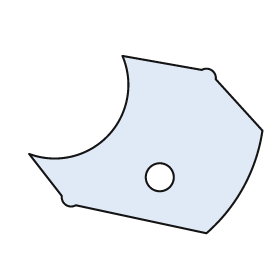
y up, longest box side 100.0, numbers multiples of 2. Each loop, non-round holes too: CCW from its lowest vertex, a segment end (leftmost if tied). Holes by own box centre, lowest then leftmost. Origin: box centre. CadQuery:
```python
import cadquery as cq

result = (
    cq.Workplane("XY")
    .moveTo(26.0, -38.0)
    .threePointArc((42.0, -18.0), (50.0, 6.0))
    .lineTo(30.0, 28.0)
    .threePointArc((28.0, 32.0), (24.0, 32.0))
    .lineTo(-10.0, 38.0)
    .threePointArc((-16.0, 4.0), (-50.0, -4.0))
    .lineTo(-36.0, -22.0)
    .threePointArc((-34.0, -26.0), (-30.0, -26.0))
    .close()
    .moveTo(6.0, -14.0)
    .circle(6.0)
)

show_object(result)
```